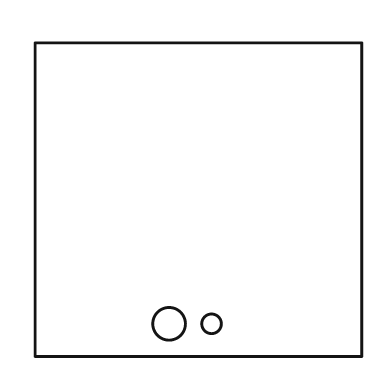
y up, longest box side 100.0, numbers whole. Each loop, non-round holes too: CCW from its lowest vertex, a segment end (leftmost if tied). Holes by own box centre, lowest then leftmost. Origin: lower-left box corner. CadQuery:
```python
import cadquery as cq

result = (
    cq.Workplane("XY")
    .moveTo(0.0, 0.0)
    .lineTo(100.0, 0.0)
    .lineTo(100.0, 96.0)
    .lineTo(0.0, 96.0)
    .close()
    .moveTo(41.0, 10.0)
    .circle(5.0)
    .moveTo(54.0, 10.0)
    .circle(3.0)
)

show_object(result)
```